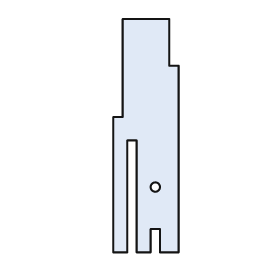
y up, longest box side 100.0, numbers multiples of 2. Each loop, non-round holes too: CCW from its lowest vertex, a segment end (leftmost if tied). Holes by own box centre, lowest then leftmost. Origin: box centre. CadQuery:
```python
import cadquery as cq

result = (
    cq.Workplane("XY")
    .moveTo(-14.0, -50.0)
    .lineTo(-8.0, -50.0)
    .lineTo(-8.0, -2.0)
    .lineTo(-4.0, -2.0)
    .lineTo(-4.0, -50.0)
    .lineTo(2.0, -50.0)
    .lineTo(2.0, -40.0)
    .lineTo(6.0, -40.0)
    .lineTo(6.0, -50.0)
    .lineTo(14.0, -50.0)
    .lineTo(14.0, 30.0)
    .lineTo(10.0, 30.0)
    .lineTo(10.0, 50.0)
    .lineTo(-10.0, 50.0)
    .lineTo(-10.0, 8.0)
    .lineTo(-14.0, 8.0)
    .close()
    .moveTo(4.0, -22.0)
    .circle(2.0)
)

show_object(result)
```